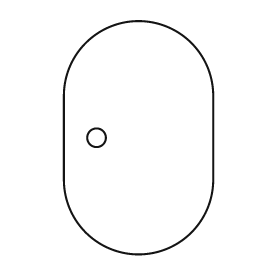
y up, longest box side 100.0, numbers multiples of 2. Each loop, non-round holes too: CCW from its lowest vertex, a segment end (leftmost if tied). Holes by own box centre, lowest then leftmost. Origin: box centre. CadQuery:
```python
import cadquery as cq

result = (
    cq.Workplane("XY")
    .moveTo(-32.0, -18.0)
    .threePointArc((0.0, -50.0), (32.0, -18.0))
    .lineTo(32.0, 18.0)
    .threePointArc((0.0, 50.0), (-32.0, 18.0))
    .close()
    .moveTo(-18.0, 0.0)
    .circle(4.0)
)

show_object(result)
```